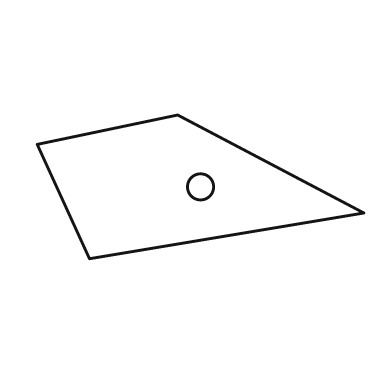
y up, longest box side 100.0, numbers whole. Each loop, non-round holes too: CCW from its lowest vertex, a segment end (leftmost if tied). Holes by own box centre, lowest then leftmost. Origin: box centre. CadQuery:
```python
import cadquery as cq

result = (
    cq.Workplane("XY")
    .moveTo(-34.0, -22.0)
    .lineTo(50.0, -8.0)
    .lineTo(-7.0, 22.0)
    .lineTo(-50.0, 13.0)
    .close()
    .moveTo(0.0, 0.0)
    .circle(4.0)
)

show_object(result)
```